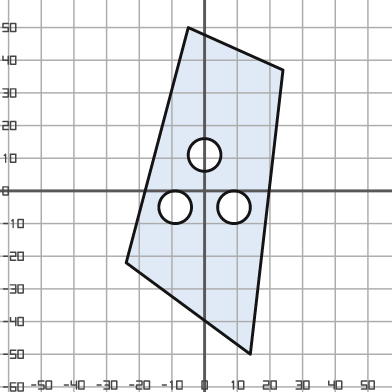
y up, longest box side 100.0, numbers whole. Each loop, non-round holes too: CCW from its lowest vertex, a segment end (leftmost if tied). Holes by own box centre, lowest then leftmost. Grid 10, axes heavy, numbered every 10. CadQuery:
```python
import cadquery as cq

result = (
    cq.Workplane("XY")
    .moveTo(14.0, -50.0)
    .lineTo(24.0, 37.0)
    .lineTo(-5.0, 50.0)
    .lineTo(-24.0, -22.0)
    .close()
    .moveTo(-9.0, -5.0)
    .circle(5.0)
    .moveTo(9.0, -5.0)
    .circle(5.0)
    .moveTo(0.0, 11.0)
    .circle(5.0)
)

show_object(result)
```